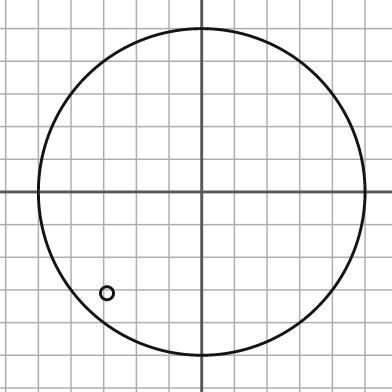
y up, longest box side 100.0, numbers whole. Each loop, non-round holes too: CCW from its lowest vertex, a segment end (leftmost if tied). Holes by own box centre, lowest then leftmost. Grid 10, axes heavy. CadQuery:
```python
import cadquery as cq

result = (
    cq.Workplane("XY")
    .moveTo(0.0, 0.0)
    .circle(50.0)
    .moveTo(-29.0, -31.0)
    .circle(2.0)
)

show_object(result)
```